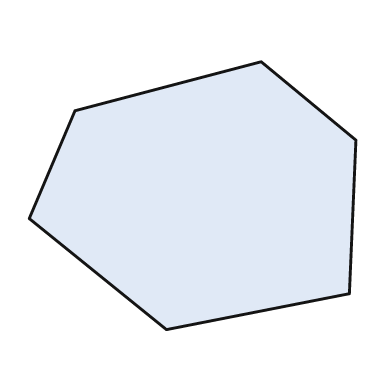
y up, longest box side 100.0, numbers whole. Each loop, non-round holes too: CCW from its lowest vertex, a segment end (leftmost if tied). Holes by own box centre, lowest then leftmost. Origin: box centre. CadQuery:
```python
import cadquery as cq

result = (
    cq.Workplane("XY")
    .moveTo(-8.0, -41.0)
    .lineTo(48.0, -30.0)
    .lineTo(50.0, 17.0)
    .lineTo(21.0, 41.0)
    .lineTo(-36.0, 26.0)
    .lineTo(-50.0, -7.0)
    .close()
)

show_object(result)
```